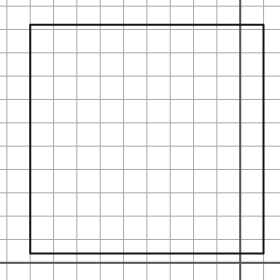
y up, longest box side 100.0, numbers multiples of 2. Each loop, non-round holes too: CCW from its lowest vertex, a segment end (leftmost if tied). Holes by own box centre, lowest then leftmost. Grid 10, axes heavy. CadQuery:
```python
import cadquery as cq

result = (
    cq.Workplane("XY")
    .moveTo(-90.0, 4.0)
    .lineTo(10.0, 4.0)
    .lineTo(10.0, 102.0)
    .lineTo(-90.0, 102.0)
    .close()
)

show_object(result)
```